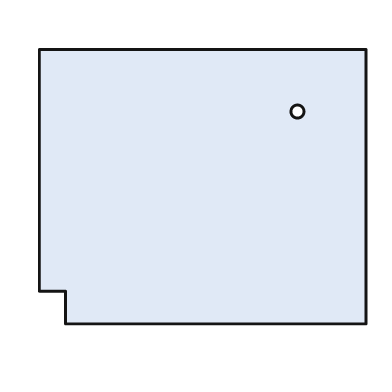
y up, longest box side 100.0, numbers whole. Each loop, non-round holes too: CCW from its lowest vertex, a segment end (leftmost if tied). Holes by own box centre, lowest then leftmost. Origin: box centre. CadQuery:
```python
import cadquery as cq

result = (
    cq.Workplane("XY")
    .moveTo(-42.0, -42.0)
    .lineTo(50.0, -42.0)
    .lineTo(50.0, 42.0)
    .lineTo(-50.0, 42.0)
    .lineTo(-50.0, -32.0)
    .lineTo(-42.0, -32.0)
    .close()
    .moveTo(29.0, 23.0)
    .circle(2.0)
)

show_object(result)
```